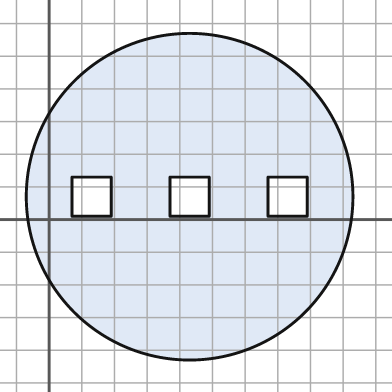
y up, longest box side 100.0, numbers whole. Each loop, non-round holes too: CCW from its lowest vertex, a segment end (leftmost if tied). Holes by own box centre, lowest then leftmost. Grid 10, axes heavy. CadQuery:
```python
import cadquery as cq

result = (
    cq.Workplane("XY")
    .moveTo(43.0, 7.0)
    .circle(50.0)
    .moveTo(7.0, 1.0)
    .lineTo(19.0, 1.0)
    .lineTo(19.0, 13.0)
    .lineTo(7.0, 13.0)
    .close()
    .moveTo(37.0, 1.0)
    .lineTo(49.0, 1.0)
    .lineTo(49.0, 13.0)
    .lineTo(37.0, 13.0)
    .close()
    .moveTo(67.0, 1.0)
    .lineTo(79.0, 1.0)
    .lineTo(79.0, 13.0)
    .lineTo(67.0, 13.0)
    .close()
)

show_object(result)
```